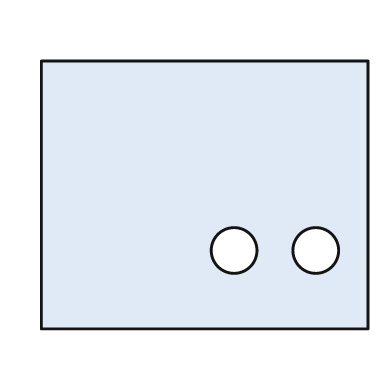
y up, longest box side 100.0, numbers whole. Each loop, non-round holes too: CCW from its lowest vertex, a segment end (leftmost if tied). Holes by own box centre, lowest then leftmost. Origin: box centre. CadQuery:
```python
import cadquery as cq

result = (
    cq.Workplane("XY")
    .moveTo(-50.0, -41.0)
    .lineTo(50.0, -41.0)
    .lineTo(50.0, 41.0)
    .lineTo(-50.0, 41.0)
    .close()
    .moveTo(9.0, -17.0)
    .circle(7.0)
    .moveTo(34.0, -17.0)
    .circle(7.0)
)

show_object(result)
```